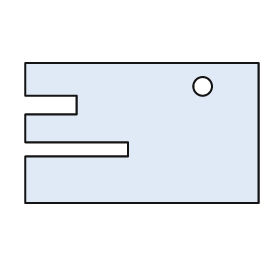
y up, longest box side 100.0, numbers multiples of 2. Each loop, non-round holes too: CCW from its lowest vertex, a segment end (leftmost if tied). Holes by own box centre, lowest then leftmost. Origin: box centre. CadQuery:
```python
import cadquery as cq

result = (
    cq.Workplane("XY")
    .moveTo(-50.0, -30.0)
    .lineTo(50.0, -30.0)
    .lineTo(50.0, 30.0)
    .lineTo(-50.0, 30.0)
    .lineTo(-50.0, 16.0)
    .lineTo(-28.0, 16.0)
    .lineTo(-28.0, 8.0)
    .lineTo(-50.0, 8.0)
    .lineTo(-50.0, -4.0)
    .lineTo(-6.0, -4.0)
    .lineTo(-6.0, -10.0)
    .lineTo(-50.0, -10.0)
    .close()
    .moveTo(26.0, 20.0)
    .circle(4.0)
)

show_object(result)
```